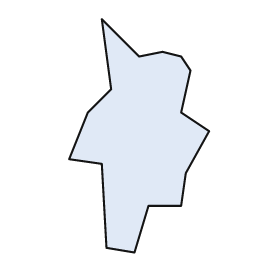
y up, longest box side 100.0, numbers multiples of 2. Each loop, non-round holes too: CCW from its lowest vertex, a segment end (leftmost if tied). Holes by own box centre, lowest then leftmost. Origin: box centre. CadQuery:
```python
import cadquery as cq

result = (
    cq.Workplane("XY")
    .moveTo(-2.0, -50.0)
    .lineTo(4.0, -30.0)
    .lineTo(18.0, -30.0)
    .lineTo(20.0, -16.0)
    .lineTo(30.0, 2.0)
    .lineTo(18.0, 10.0)
    .lineTo(22.0, 28.0)
    .lineTo(18.0, 34.0)
    .lineTo(10.0, 36.0)
    .lineTo(0.0, 34.0)
    .lineTo(-16.0, 50.0)
    .lineTo(-12.0, 20.0)
    .lineTo(-22.0, 10.0)
    .lineTo(-30.0, -10.0)
    .lineTo(-16.0, -12.0)
    .lineTo(-14.0, -48.0)
    .close()
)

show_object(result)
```